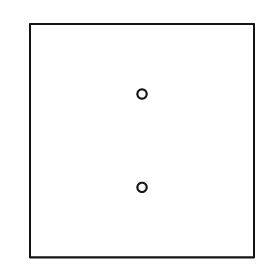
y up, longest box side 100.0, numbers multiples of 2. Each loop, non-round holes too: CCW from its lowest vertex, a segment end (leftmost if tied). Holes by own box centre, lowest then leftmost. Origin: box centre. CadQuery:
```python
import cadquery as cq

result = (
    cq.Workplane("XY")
    .moveTo(-48.0, -50.0)
    .lineTo(48.0, -50.0)
    .lineTo(48.0, 50.0)
    .lineTo(-48.0, 50.0)
    .close()
    .moveTo(0.0, -20.0)
    .circle(2.0)
    .moveTo(0.0, 20.0)
    .circle(2.0)
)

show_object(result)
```